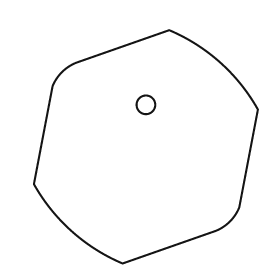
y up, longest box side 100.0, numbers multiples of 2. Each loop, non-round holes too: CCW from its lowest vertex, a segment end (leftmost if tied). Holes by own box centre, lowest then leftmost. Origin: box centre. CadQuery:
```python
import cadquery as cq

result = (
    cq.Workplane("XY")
    .moveTo(-10.0, -50.0)
    .lineTo(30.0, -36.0)
    .threePointArc((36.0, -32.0), (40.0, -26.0))
    .lineTo(48.0, 16.0)
    .threePointArc((32.0, 36.0), (10.0, 50.0))
    .lineTo(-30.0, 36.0)
    .threePointArc((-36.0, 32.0), (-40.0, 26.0))
    .lineTo(-48.0, -16.0)
    .threePointArc((-32.0, -36.0), (-10.0, -50.0))
    .close()
    .moveTo(0.0, 18.0)
    .circle(4.0)
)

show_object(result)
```